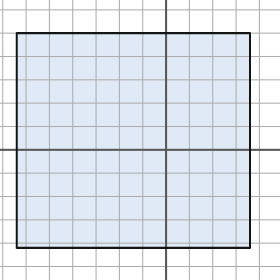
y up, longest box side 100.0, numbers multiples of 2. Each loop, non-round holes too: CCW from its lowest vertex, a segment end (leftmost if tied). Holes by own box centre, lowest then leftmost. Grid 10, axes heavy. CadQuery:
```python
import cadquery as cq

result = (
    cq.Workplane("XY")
    .moveTo(-64.0, -42.0)
    .lineTo(36.0, -42.0)
    .lineTo(36.0, 50.0)
    .lineTo(-64.0, 50.0)
    .close()
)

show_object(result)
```